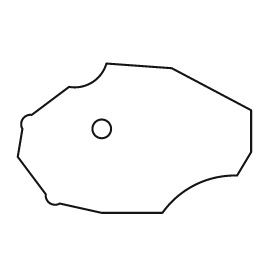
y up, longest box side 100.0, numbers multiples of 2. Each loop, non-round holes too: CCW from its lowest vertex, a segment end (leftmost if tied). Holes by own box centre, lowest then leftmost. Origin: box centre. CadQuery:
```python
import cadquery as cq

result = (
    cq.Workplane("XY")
    .moveTo(-14.0, -32.0)
    .lineTo(12.0, -32.0)
    .threePointArc((26.0, -20.0), (44.0, -16.0))
    .lineTo(50.0, -6.0)
    .lineTo(50.0, 12.0)
    .lineTo(16.0, 30.0)
    .lineTo(-12.0, 32.0)
    .threePointArc((-18.0, 24.0), (-28.0, 22.0))
    .lineTo(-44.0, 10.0)
    .threePointArc((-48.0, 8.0), (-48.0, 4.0))
    .lineTo(-50.0, -8.0)
    .lineTo(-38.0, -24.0)
    .threePointArc((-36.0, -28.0), (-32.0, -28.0))
    .close()
    .moveTo(-14.0, 4.0)
    .circle(4.0)
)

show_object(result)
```